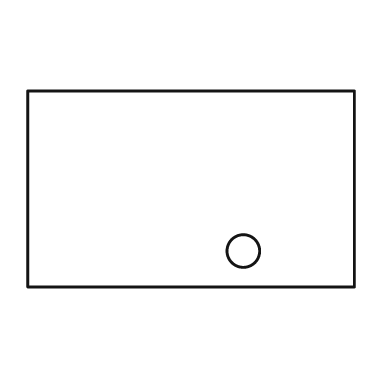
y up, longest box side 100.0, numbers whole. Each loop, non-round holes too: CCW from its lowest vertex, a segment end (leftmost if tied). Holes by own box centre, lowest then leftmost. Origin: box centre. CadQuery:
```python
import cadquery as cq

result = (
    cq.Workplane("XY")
    .moveTo(-50.0, -30.0)
    .lineTo(50.0, -30.0)
    .lineTo(50.0, 30.0)
    .lineTo(-50.0, 30.0)
    .close()
    .moveTo(16.0, -19.0)
    .circle(5.0)
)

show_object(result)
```